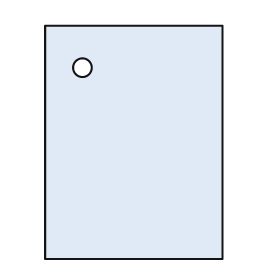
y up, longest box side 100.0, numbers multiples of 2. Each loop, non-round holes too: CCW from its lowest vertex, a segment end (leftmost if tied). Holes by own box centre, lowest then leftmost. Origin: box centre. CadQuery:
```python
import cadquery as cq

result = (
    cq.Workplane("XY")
    .moveTo(-38.0, -50.0)
    .lineTo(38.0, -50.0)
    .lineTo(38.0, 50.0)
    .lineTo(-38.0, 50.0)
    .close()
    .moveTo(-22.0, 32.0)
    .circle(4.0)
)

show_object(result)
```